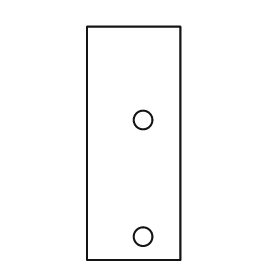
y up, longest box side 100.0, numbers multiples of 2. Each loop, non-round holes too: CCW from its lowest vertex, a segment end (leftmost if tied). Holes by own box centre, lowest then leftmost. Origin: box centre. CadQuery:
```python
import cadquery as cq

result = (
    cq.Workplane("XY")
    .moveTo(-20.0, -50.0)
    .lineTo(20.0, -50.0)
    .lineTo(20.0, 50.0)
    .lineTo(-20.0, 50.0)
    .close()
    .moveTo(4.0, -40.0)
    .circle(4.0)
    .moveTo(4.0, 10.0)
    .circle(4.0)
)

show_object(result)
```